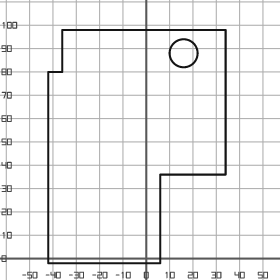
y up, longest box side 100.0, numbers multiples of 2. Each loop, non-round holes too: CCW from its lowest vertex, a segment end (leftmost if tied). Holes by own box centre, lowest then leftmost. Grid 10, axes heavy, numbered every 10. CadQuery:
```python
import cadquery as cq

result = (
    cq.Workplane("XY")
    .moveTo(-42.0, -2.0)
    .lineTo(6.0, -2.0)
    .lineTo(6.0, 36.0)
    .lineTo(34.0, 36.0)
    .lineTo(34.0, 98.0)
    .lineTo(-36.0, 98.0)
    .lineTo(-36.0, 80.0)
    .lineTo(-42.0, 80.0)
    .close()
    .moveTo(16.0, 88.0)
    .circle(6.0)
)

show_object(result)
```